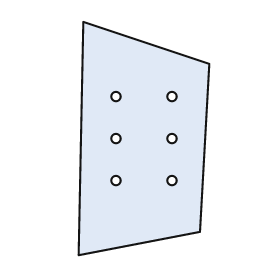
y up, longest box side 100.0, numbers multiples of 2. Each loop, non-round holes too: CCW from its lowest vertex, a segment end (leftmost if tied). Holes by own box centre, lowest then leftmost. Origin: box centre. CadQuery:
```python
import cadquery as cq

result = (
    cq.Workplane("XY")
    .moveTo(-28.0, -50.0)
    .lineTo(24.0, -40.0)
    .lineTo(28.0, 32.0)
    .lineTo(-26.0, 50.0)
    .close()
    .moveTo(-12.0, -18.0)
    .circle(2.0)
    .moveTo(12.0, -18.0)
    .circle(2.0)
    .moveTo(-12.0, 0.0)
    .circle(2.0)
    .moveTo(12.0, 0.0)
    .circle(2.0)
    .moveTo(-12.0, 18.0)
    .circle(2.0)
    .moveTo(12.0, 18.0)
    .circle(2.0)
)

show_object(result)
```